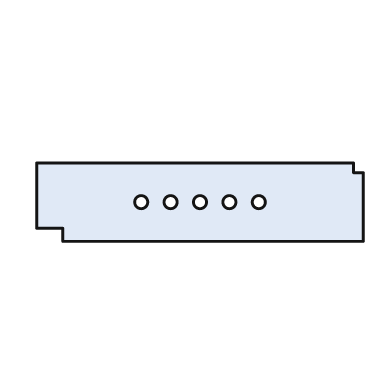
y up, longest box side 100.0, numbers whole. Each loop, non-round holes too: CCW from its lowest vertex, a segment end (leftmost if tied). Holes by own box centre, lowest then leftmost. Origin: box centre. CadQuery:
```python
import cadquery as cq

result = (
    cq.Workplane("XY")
    .moveTo(-42.0, -12.0)
    .lineTo(50.0, -12.0)
    .lineTo(50.0, 9.0)
    .lineTo(47.0, 9.0)
    .lineTo(47.0, 12.0)
    .lineTo(-50.0, 12.0)
    .lineTo(-50.0, -8.0)
    .lineTo(-42.0, -8.0)
    .close()
    .moveTo(-18.0, 0.0)
    .circle(2.0)
    .moveTo(-9.0, 0.0)
    .circle(2.0)
    .moveTo(0.0, 0.0)
    .circle(2.0)
    .moveTo(9.0, 0.0)
    .circle(2.0)
    .moveTo(18.0, 0.0)
    .circle(2.0)
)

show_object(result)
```